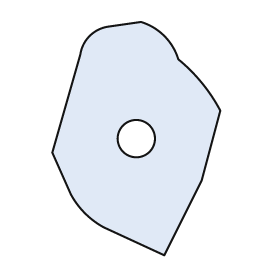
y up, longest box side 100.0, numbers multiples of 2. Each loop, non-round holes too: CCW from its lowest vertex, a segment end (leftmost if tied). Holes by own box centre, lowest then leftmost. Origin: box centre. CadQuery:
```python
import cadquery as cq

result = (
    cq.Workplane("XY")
    .moveTo(12.0, -50.0)
    .lineTo(28.0, -18.0)
    .lineTo(36.0, 12.0)
    .threePointArc((28.0, 24.0), (18.0, 34.0))
    .threePointArc((12.0, 44.0), (2.0, 50.0))
    .lineTo(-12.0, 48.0)
    .threePointArc((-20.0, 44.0), (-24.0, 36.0))
    .lineTo(-36.0, -6.0)
    .lineTo(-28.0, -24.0)
    .threePointArc((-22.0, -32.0), (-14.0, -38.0))
    .close()
    .moveTo(0.0, 0.0)
    .circle(8.0)
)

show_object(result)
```